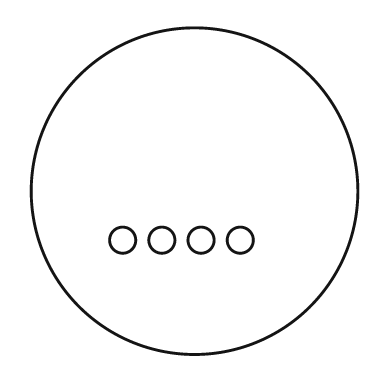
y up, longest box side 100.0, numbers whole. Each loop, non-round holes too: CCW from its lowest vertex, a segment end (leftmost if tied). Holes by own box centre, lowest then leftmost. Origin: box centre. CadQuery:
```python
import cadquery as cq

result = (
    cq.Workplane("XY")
    .moveTo(0.0, 0.0)
    .circle(50.0)
    .moveTo(-22.0, -15.0)
    .circle(4.0)
    .moveTo(-10.0, -15.0)
    .circle(4.0)
    .moveTo(2.0, -15.0)
    .circle(4.0)
    .moveTo(14.0, -15.0)
    .circle(4.0)
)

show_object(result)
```